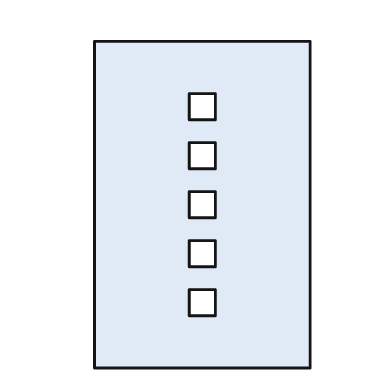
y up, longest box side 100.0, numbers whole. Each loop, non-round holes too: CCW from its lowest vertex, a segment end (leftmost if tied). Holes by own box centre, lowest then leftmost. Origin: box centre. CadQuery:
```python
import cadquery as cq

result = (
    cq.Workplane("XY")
    .moveTo(-33.0, -50.0)
    .lineTo(33.0, -50.0)
    .lineTo(33.0, 50.0)
    .lineTo(-33.0, 50.0)
    .close()
    .moveTo(-4.0, -34.0)
    .lineTo(4.0, -34.0)
    .lineTo(4.0, -26.0)
    .lineTo(-4.0, -26.0)
    .close()
    .moveTo(-4.0, -19.0)
    .lineTo(4.0, -19.0)
    .lineTo(4.0, -11.0)
    .lineTo(-4.0, -11.0)
    .close()
    .moveTo(-4.0, -4.0)
    .lineTo(4.0, -4.0)
    .lineTo(4.0, 4.0)
    .lineTo(-4.0, 4.0)
    .close()
    .moveTo(-4.0, 11.0)
    .lineTo(4.0, 11.0)
    .lineTo(4.0, 19.0)
    .lineTo(-4.0, 19.0)
    .close()
    .moveTo(-4.0, 26.0)
    .lineTo(4.0, 26.0)
    .lineTo(4.0, 34.0)
    .lineTo(-4.0, 34.0)
    .close()
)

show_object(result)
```